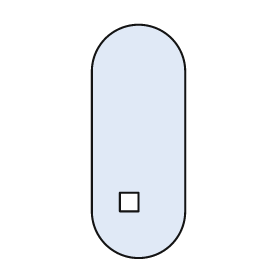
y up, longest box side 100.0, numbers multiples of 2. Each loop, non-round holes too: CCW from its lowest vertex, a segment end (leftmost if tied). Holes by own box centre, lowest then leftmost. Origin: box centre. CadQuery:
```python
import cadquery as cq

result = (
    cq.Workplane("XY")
    .moveTo(-20.0, -30.0)
    .threePointArc((0.0, -50.0), (20.0, -30.0))
    .lineTo(20.0, 30.0)
    .threePointArc((0.0, 50.0), (-20.0, 30.0))
    .close()
    .moveTo(-8.0, -30.0)
    .lineTo(0.0, -30.0)
    .lineTo(0.0, -22.0)
    .lineTo(-8.0, -22.0)
    .close()
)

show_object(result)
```